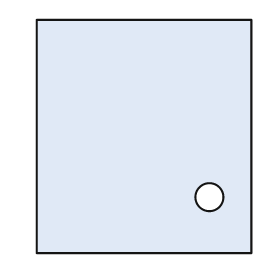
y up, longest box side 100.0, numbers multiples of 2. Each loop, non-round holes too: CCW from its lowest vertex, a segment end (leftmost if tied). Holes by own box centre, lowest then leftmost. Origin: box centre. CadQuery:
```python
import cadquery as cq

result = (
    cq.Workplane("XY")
    .moveTo(-46.0, -50.0)
    .lineTo(46.0, -50.0)
    .lineTo(46.0, 50.0)
    .lineTo(-46.0, 50.0)
    .close()
    .moveTo(28.0, -26.0)
    .circle(6.0)
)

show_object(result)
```